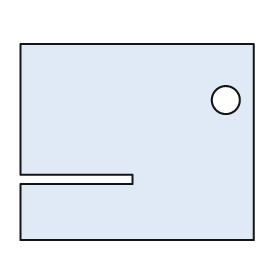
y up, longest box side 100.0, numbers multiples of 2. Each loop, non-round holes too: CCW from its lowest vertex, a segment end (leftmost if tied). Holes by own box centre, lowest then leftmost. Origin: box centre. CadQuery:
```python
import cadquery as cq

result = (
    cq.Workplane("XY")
    .moveTo(-50.0, -42.0)
    .lineTo(50.0, -42.0)
    .lineTo(50.0, 42.0)
    .lineTo(-50.0, 42.0)
    .lineTo(-50.0, -14.0)
    .lineTo(-2.0, -14.0)
    .lineTo(-2.0, -18.0)
    .lineTo(-50.0, -18.0)
    .close()
    .moveTo(38.0, 18.0)
    .circle(6.0)
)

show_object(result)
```